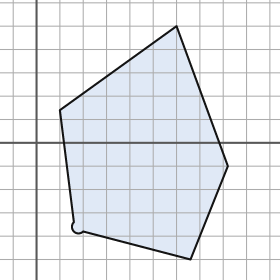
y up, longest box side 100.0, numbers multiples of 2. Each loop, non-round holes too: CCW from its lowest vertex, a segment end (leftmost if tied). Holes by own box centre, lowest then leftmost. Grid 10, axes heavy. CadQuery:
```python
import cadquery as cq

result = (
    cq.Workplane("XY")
    .moveTo(66.0, -50.0)
    .lineTo(82.0, -10.0)
    .lineTo(60.0, 50.0)
    .lineTo(10.0, 14.0)
    .lineTo(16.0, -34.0)
    .threePointArc((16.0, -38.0), (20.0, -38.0))
    .close()
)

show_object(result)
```